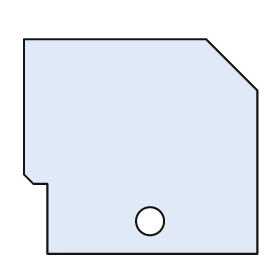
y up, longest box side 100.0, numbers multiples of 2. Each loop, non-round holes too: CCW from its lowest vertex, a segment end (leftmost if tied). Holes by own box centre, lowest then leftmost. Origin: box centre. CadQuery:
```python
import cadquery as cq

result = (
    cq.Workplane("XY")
    .moveTo(-40.0, -46.0)
    .lineTo(50.0, -46.0)
    .lineTo(50.0, 24.0)
    .lineTo(28.0, 46.0)
    .lineTo(-50.0, 46.0)
    .lineTo(-50.0, -12.0)
    .lineTo(-46.0, -16.0)
    .lineTo(-40.0, -16.0)
    .close()
    .moveTo(4.0, -32.0)
    .circle(6.0)
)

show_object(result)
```